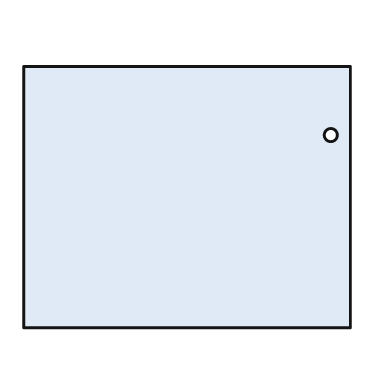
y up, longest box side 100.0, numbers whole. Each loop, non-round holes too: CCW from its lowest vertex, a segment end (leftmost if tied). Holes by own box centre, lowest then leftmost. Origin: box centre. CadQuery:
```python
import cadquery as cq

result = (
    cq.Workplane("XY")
    .moveTo(-50.0, -40.0)
    .lineTo(50.0, -40.0)
    .lineTo(50.0, 40.0)
    .lineTo(-50.0, 40.0)
    .close()
    .moveTo(44.0, 19.0)
    .circle(2.0)
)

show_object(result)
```